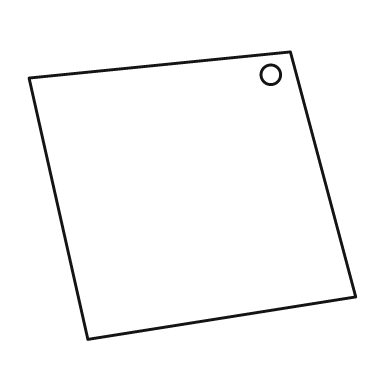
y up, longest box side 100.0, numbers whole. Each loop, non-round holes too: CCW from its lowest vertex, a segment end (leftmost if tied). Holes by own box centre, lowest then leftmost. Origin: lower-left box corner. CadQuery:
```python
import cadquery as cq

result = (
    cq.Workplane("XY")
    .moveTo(18.0, 0.0)
    .lineTo(100.0, 13.0)
    .lineTo(80.0, 88.0)
    .lineTo(0.0, 80.0)
    .close()
    .moveTo(74.0, 81.0)
    .circle(3.0)
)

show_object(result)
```